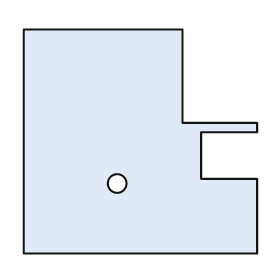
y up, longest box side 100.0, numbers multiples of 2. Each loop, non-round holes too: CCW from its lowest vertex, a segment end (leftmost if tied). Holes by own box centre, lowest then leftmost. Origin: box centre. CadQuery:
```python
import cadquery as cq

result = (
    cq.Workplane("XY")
    .moveTo(-50.0, -48.0)
    .lineTo(50.0, -48.0)
    .lineTo(50.0, -16.0)
    .lineTo(26.0, -16.0)
    .lineTo(26.0, 4.0)
    .lineTo(50.0, 4.0)
    .lineTo(50.0, 8.0)
    .lineTo(18.0, 8.0)
    .lineTo(18.0, 48.0)
    .lineTo(-50.0, 48.0)
    .close()
    .moveTo(-10.0, -18.0)
    .circle(4.0)
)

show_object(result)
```